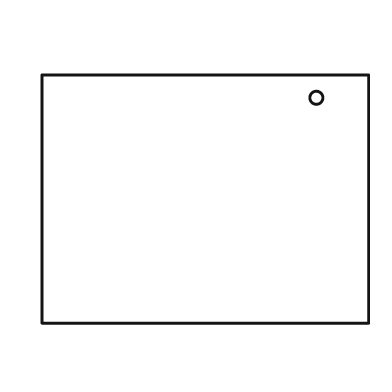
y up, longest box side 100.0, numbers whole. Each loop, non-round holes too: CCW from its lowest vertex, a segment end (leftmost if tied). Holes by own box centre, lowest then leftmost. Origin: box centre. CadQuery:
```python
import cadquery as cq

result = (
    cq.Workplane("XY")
    .moveTo(-50.0, -38.0)
    .lineTo(50.0, -38.0)
    .lineTo(50.0, 38.0)
    .lineTo(-50.0, 38.0)
    .close()
    .moveTo(34.0, 31.0)
    .circle(2.0)
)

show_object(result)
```